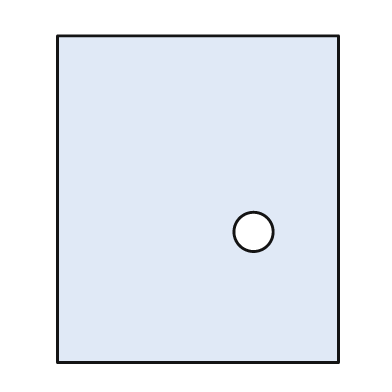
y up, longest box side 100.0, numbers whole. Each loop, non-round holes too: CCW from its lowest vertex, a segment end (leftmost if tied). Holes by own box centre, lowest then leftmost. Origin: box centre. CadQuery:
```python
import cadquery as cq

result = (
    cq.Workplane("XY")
    .moveTo(-43.0, -50.0)
    .lineTo(43.0, -50.0)
    .lineTo(43.0, 50.0)
    .lineTo(-43.0, 50.0)
    .close()
    .moveTo(17.0, -10.0)
    .circle(6.0)
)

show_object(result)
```